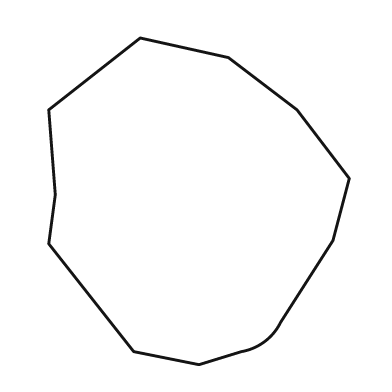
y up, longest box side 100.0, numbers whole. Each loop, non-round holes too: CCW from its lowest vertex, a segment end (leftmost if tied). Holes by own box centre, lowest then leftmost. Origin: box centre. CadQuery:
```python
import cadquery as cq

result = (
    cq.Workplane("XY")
    .moveTo(0.0, -50.0)
    .lineTo(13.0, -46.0)
    .threePointArc((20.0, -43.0), (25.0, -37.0))
    .lineTo(41.0, -12.0)
    .lineTo(46.0, 7.0)
    .lineTo(30.0, 28.0)
    .lineTo(9.0, 44.0)
    .lineTo(-18.0, 50.0)
    .lineTo(-46.0, 28.0)
    .lineTo(-44.0, 2.0)
    .lineTo(-46.0, -13.0)
    .lineTo(-20.0, -46.0)
    .close()
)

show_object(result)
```